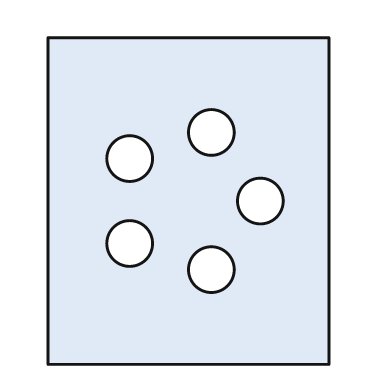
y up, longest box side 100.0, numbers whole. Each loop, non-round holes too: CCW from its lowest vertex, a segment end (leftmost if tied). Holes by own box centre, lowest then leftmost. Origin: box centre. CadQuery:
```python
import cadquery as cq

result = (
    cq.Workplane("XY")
    .moveTo(-43.0, -50.0)
    .lineTo(43.0, -50.0)
    .lineTo(43.0, 50.0)
    .lineTo(-43.0, 50.0)
    .close()
    .moveTo(7.0, -21.0)
    .circle(7.0)
    .moveTo(-18.0, -13.0)
    .circle(7.0)
    .moveTo(22.0, 0.0)
    .circle(7.0)
    .moveTo(-18.0, 13.0)
    .circle(7.0)
    .moveTo(7.0, 21.0)
    .circle(7.0)
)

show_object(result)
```